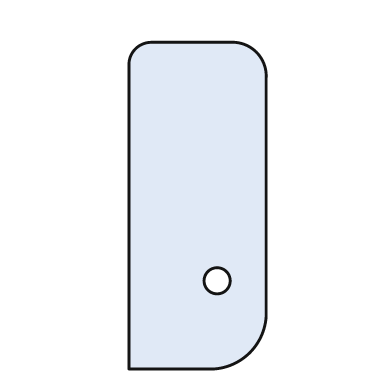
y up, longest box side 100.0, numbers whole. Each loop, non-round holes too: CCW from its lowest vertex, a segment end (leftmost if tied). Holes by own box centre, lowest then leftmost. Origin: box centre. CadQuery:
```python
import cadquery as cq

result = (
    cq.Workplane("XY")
    .moveTo(-21.0, -50.0)
    .lineTo(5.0, -50.0)
    .threePointArc((16.0, -45.0), (21.0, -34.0))
    .lineTo(21.0, 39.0)
    .threePointArc((18.0, 47.0), (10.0, 50.0))
    .lineTo(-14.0, 50.0)
    .threePointArc((-19.0, 48.0), (-21.0, 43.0))
    .close()
    .moveTo(6.0, -23.0)
    .circle(4.0)
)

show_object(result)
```